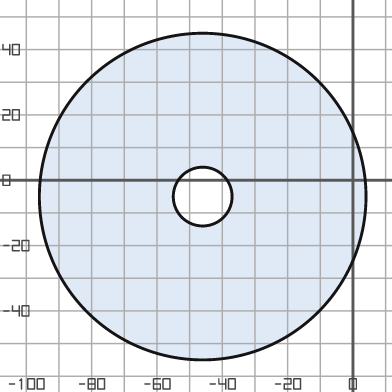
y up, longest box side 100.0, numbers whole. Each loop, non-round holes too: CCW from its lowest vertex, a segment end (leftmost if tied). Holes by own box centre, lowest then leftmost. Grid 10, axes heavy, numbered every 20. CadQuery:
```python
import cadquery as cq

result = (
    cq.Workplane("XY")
    .moveTo(-46.0, -5.0)
    .circle(50.0)
    .moveTo(-46.0, -5.0)
    .circle(9.0)
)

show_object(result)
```